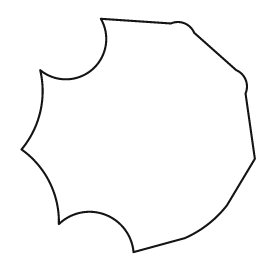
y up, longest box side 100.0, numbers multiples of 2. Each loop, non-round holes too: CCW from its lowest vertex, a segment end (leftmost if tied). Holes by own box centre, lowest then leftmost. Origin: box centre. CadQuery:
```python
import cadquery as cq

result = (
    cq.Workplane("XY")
    .moveTo(-2.0, -50.0)
    .lineTo(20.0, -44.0)
    .threePointArc((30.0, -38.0), (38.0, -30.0))
    .lineTo(50.0, -10.0)
    .lineTo(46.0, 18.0)
    .threePointArc((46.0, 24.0), (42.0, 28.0))
    .lineTo(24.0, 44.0)
    .threePointArc((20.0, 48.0), (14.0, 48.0))
    .lineTo(-16.0, 50.0)
    .threePointArc((-20.0, 28.0), (-42.0, 28.0))
    .threePointArc((-42.0, 10.0), (-50.0, -6.0))
    .threePointArc((-38.0, -20.0), (-34.0, -38.0))
    .threePointArc((-14.0, -34.0), (-2.0, -50.0))
    .close()
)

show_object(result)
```